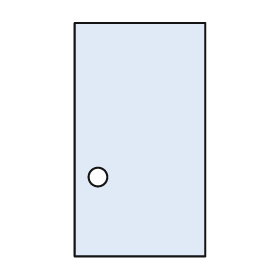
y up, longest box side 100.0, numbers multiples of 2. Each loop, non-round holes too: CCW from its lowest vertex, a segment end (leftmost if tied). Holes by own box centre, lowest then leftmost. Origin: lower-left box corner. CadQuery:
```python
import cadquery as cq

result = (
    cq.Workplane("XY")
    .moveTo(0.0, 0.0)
    .lineTo(56.0, 0.0)
    .lineTo(56.0, 100.0)
    .lineTo(0.0, 100.0)
    .close()
    .moveTo(10.0, 34.0)
    .circle(4.0)
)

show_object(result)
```